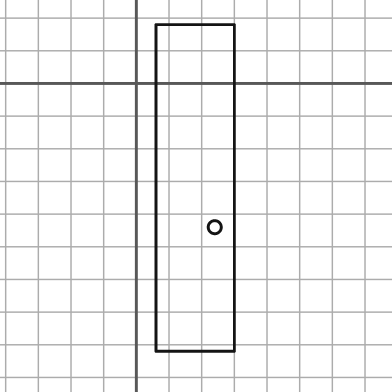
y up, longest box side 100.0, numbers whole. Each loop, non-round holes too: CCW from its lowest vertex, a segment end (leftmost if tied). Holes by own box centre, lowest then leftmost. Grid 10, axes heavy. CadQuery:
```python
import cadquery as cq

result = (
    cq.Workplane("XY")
    .moveTo(6.0, -82.0)
    .lineTo(30.0, -82.0)
    .lineTo(30.0, 18.0)
    .lineTo(6.0, 18.0)
    .close()
    .moveTo(24.0, -44.0)
    .circle(2.0)
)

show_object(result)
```